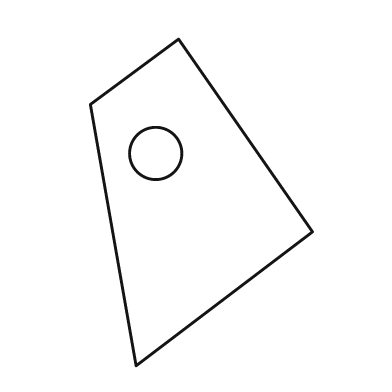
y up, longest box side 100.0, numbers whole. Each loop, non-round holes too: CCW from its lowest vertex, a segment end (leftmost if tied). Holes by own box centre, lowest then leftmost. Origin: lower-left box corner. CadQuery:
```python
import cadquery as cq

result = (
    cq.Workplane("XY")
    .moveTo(14.0, 0.0)
    .lineTo(68.0, 41.0)
    .lineTo(27.0, 100.0)
    .lineTo(0.0, 80.0)
    .close()
    .moveTo(20.0, 65.0)
    .circle(8.0)
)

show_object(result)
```